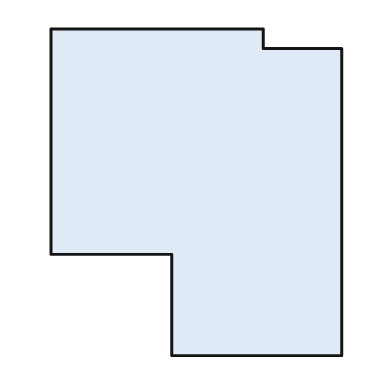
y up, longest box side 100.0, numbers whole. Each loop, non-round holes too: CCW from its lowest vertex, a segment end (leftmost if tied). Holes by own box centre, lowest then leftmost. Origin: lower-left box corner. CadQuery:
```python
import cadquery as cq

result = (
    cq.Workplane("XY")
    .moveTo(37.0, 0.0)
    .lineTo(89.0, 0.0)
    .lineTo(89.0, 94.0)
    .lineTo(65.0, 94.0)
    .lineTo(65.0, 100.0)
    .lineTo(0.0, 100.0)
    .lineTo(0.0, 31.0)
    .lineTo(37.0, 31.0)
    .close()
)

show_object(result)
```